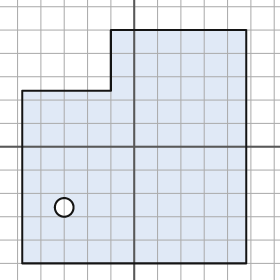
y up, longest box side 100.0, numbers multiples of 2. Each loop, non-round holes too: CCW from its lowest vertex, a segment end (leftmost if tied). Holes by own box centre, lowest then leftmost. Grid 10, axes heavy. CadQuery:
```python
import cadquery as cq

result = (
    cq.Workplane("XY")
    .moveTo(-48.0, -50.0)
    .lineTo(48.0, -50.0)
    .lineTo(48.0, 50.0)
    .lineTo(-10.0, 50.0)
    .lineTo(-10.0, 24.0)
    .lineTo(-48.0, 24.0)
    .close()
    .moveTo(-30.0, -26.0)
    .circle(4.0)
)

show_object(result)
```